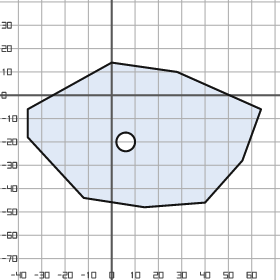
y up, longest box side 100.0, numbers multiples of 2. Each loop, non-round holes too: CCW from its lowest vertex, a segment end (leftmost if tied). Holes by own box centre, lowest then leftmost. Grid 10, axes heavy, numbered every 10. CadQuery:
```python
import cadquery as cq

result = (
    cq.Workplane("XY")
    .moveTo(14.0, -48.0)
    .lineTo(40.0, -46.0)
    .lineTo(56.0, -28.0)
    .lineTo(64.0, -6.0)
    .lineTo(28.0, 10.0)
    .lineTo(0.0, 14.0)
    .lineTo(-36.0, -6.0)
    .lineTo(-36.0, -18.0)
    .lineTo(-12.0, -44.0)
    .close()
    .moveTo(6.0, -20.0)
    .circle(4.0)
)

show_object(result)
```